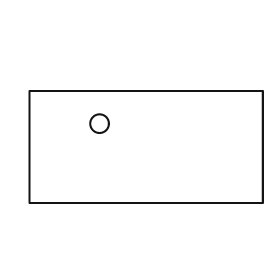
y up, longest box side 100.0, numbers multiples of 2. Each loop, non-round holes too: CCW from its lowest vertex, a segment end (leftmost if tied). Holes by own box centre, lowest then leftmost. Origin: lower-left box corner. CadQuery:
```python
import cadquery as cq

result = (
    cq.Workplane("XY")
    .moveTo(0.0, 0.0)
    .lineTo(100.0, 0.0)
    .lineTo(100.0, 48.0)
    .lineTo(0.0, 48.0)
    .close()
    .moveTo(30.0, 34.0)
    .circle(4.0)
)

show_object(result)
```